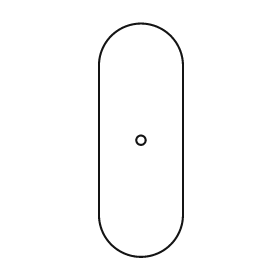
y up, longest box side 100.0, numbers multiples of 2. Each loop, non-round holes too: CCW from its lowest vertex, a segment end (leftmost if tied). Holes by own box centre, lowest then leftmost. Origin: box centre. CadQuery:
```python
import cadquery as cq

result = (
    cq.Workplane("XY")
    .moveTo(-18.0, -32.0)
    .threePointArc((0.0, -50.0), (18.0, -32.0))
    .lineTo(18.0, 32.0)
    .threePointArc((0.0, 50.0), (-18.0, 32.0))
    .close()
    .moveTo(0.0, 0.0)
    .circle(2.0)
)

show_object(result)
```